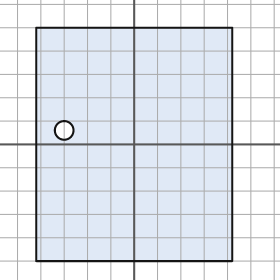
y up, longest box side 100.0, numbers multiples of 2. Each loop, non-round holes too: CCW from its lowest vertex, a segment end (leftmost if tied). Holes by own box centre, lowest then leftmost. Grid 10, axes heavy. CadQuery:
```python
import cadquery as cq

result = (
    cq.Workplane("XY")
    .moveTo(-42.0, -50.0)
    .lineTo(42.0, -50.0)
    .lineTo(42.0, 50.0)
    .lineTo(-42.0, 50.0)
    .close()
    .moveTo(-30.0, 6.0)
    .circle(4.0)
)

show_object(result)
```